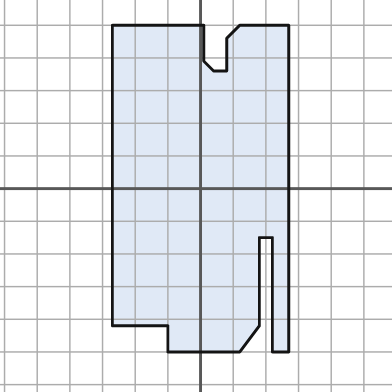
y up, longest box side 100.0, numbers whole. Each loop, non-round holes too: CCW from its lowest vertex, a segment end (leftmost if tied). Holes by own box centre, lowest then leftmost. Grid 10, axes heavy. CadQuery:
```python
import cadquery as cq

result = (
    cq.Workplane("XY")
    .moveTo(-10.0, -50.0)
    .lineTo(12.0, -50.0)
    .lineTo(18.0, -42.0)
    .lineTo(18.0, -15.0)
    .lineTo(22.0, -15.0)
    .lineTo(22.0, -50.0)
    .lineTo(27.0, -50.0)
    .lineTo(27.0, 50.0)
    .lineTo(12.0, 50.0)
    .lineTo(8.0, 46.0)
    .lineTo(8.0, 36.0)
    .lineTo(4.0, 36.0)
    .lineTo(1.0, 39.0)
    .lineTo(1.0, 50.0)
    .lineTo(-27.0, 50.0)
    .lineTo(-27.0, -42.0)
    .lineTo(-10.0, -42.0)
    .close()
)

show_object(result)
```